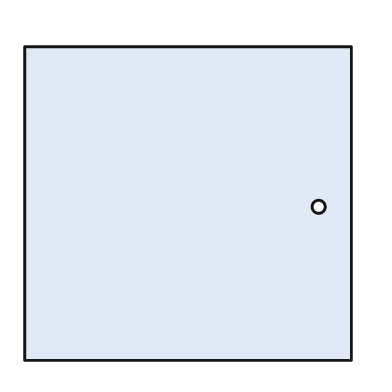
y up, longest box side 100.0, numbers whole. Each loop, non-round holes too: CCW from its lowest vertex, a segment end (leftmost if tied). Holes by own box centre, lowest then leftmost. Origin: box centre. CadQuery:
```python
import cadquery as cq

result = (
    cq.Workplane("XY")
    .moveTo(-50.0, -48.0)
    .lineTo(50.0, -48.0)
    .lineTo(50.0, 48.0)
    .lineTo(-50.0, 48.0)
    .close()
    .moveTo(40.0, -1.0)
    .circle(2.0)
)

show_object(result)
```